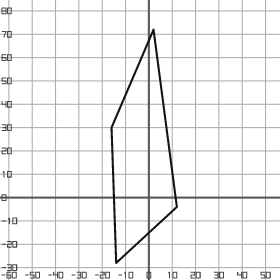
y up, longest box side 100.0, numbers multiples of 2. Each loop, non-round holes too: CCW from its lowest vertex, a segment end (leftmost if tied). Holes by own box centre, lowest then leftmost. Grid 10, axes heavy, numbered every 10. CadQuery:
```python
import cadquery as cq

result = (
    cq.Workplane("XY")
    .moveTo(-14.0, -28.0)
    .lineTo(12.0, -4.0)
    .lineTo(2.0, 72.0)
    .lineTo(-16.0, 30.0)
    .close()
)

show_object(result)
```